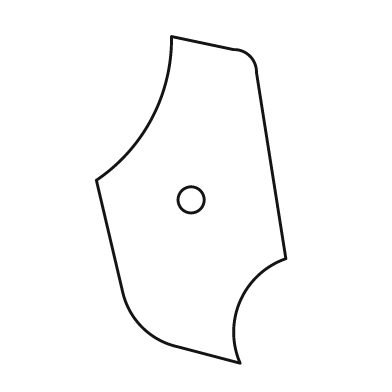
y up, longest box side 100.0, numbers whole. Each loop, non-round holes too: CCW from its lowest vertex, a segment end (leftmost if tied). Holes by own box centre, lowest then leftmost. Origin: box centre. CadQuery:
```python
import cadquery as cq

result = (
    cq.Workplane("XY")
    .moveTo(15.0, -50.0)
    .threePointArc((15.0, -31.0), (29.0, -18.0))
    .lineTo(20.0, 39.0)
    .threePointArc((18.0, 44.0), (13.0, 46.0))
    .lineTo(-6.0, 50.0)
    .threePointArc((-12.0, 25.0), (-29.0, 6.0))
    .lineTo(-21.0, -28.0)
    .threePointArc((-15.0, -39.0), (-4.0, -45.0))
    .close()
    .moveTo(0.0, 0.0)
    .circle(4.0)
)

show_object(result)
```